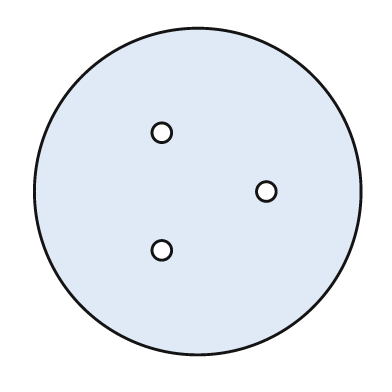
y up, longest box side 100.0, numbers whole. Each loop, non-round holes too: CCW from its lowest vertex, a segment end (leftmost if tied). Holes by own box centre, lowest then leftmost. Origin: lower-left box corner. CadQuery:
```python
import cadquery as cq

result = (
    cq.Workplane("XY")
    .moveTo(50.0, 50.0)
    .circle(50.0)
    .moveTo(39.0, 32.0)
    .circle(3.0)
    .moveTo(71.0, 50.0)
    .circle(3.0)
    .moveTo(39.0, 68.0)
    .circle(3.0)
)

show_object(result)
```